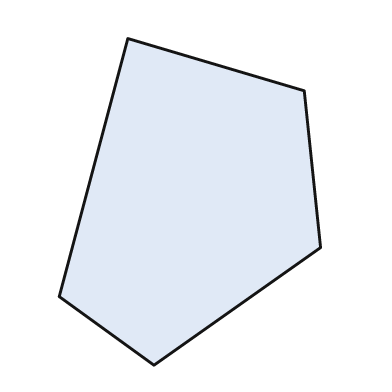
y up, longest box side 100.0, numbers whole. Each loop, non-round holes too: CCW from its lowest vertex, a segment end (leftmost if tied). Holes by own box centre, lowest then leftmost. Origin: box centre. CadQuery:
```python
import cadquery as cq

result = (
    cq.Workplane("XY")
    .moveTo(-11.0, -50.0)
    .lineTo(40.0, -14.0)
    .lineTo(35.0, 34.0)
    .lineTo(-19.0, 50.0)
    .lineTo(-40.0, -29.0)
    .close()
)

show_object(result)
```